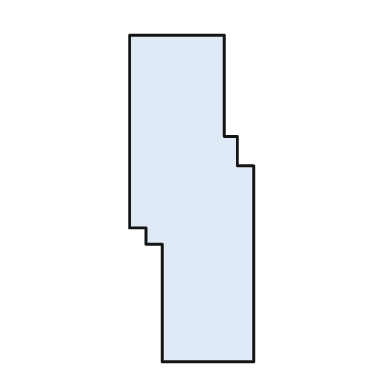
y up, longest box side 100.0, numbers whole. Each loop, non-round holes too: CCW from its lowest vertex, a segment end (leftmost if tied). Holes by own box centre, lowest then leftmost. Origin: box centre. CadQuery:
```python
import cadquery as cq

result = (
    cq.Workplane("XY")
    .moveTo(-9.0, -50.0)
    .lineTo(19.0, -50.0)
    .lineTo(19.0, 10.0)
    .lineTo(14.0, 10.0)
    .lineTo(14.0, 19.0)
    .lineTo(10.0, 19.0)
    .lineTo(10.0, 50.0)
    .lineTo(-19.0, 50.0)
    .lineTo(-19.0, -9.0)
    .lineTo(-14.0, -9.0)
    .lineTo(-14.0, -14.0)
    .lineTo(-9.0, -14.0)
    .close()
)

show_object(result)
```